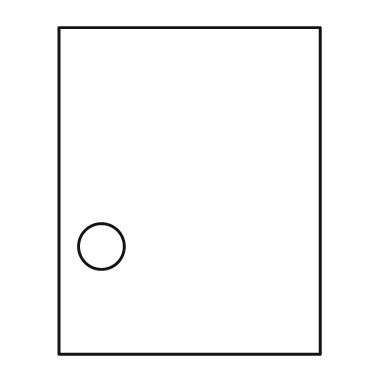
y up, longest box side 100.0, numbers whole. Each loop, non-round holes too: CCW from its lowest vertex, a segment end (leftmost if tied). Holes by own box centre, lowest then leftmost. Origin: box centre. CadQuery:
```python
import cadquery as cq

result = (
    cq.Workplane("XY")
    .moveTo(-40.0, -50.0)
    .lineTo(40.0, -50.0)
    .lineTo(40.0, 50.0)
    .lineTo(-40.0, 50.0)
    .close()
    .moveTo(-27.0, -17.0)
    .circle(7.0)
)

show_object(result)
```